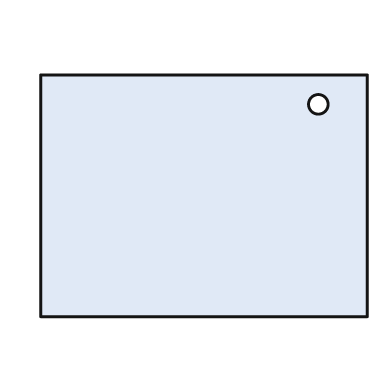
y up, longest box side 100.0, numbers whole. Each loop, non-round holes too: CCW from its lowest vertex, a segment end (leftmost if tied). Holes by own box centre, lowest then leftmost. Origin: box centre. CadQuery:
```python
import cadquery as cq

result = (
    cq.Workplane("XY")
    .moveTo(-50.0, -37.0)
    .lineTo(50.0, -37.0)
    .lineTo(50.0, 37.0)
    .lineTo(-50.0, 37.0)
    .close()
    .moveTo(35.0, 28.0)
    .circle(3.0)
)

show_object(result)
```